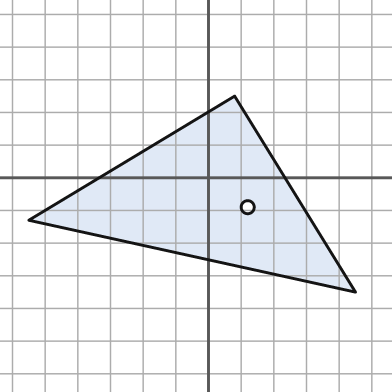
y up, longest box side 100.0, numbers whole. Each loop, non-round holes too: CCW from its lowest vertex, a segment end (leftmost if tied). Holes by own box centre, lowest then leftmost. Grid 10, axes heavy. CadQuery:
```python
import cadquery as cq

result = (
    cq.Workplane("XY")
    .moveTo(45.0, -35.0)
    .lineTo(8.0, 25.0)
    .lineTo(-55.0, -13.0)
    .close()
    .moveTo(12.0, -9.0)
    .circle(2.0)
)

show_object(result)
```